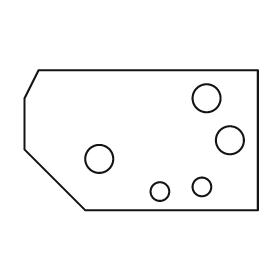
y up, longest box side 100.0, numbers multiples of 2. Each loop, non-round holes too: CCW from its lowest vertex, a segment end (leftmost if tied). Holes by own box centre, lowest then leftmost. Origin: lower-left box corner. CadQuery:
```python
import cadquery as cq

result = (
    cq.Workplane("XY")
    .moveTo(26.0, 0.0)
    .lineTo(100.0, 0.0)
    .lineTo(100.0, 60.0)
    .lineTo(6.0, 60.0)
    .lineTo(0.0, 48.0)
    .lineTo(0.0, 26.0)
    .close()
    .moveTo(58.0, 8.0)
    .circle(4.0)
    .moveTo(76.0, 10.0)
    .circle(4.0)
    .moveTo(32.0, 22.0)
    .circle(6.0)
    .moveTo(88.0, 30.0)
    .circle(6.0)
    .moveTo(78.0, 48.0)
    .circle(6.0)
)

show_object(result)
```